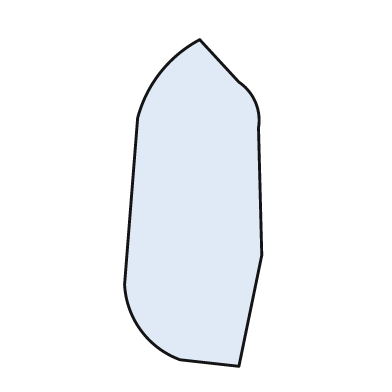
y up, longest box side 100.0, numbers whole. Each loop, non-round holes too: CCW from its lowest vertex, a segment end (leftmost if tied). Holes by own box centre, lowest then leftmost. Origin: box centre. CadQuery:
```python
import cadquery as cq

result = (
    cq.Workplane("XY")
    .moveTo(14.0, -50.0)
    .lineTo(21.0, -16.0)
    .lineTo(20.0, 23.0)
    .threePointArc((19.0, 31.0), (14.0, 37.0))
    .lineTo(2.0, 50.0)
    .threePointArc((-10.0, 40.0), (-17.0, 26.0))
    .lineTo(-21.0, -25.0)
    .threePointArc((-16.0, -39.0), (-4.0, -48.0))
    .close()
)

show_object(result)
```